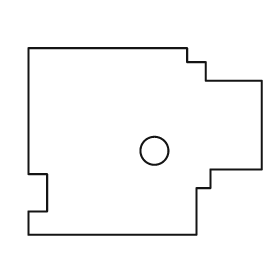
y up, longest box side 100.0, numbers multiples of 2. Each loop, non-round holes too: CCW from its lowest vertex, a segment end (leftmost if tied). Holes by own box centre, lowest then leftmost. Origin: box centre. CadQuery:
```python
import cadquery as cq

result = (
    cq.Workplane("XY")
    .moveTo(-50.0, -40.0)
    .lineTo(22.0, -40.0)
    .lineTo(22.0, -20.0)
    .lineTo(28.0, -20.0)
    .lineTo(28.0, -12.0)
    .lineTo(50.0, -12.0)
    .lineTo(50.0, 26.0)
    .lineTo(26.0, 26.0)
    .lineTo(26.0, 34.0)
    .lineTo(18.0, 34.0)
    .lineTo(18.0, 40.0)
    .lineTo(-50.0, 40.0)
    .lineTo(-50.0, -14.0)
    .lineTo(-42.0, -14.0)
    .lineTo(-42.0, -30.0)
    .lineTo(-50.0, -30.0)
    .close()
    .moveTo(4.0, -4.0)
    .circle(6.0)
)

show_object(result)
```